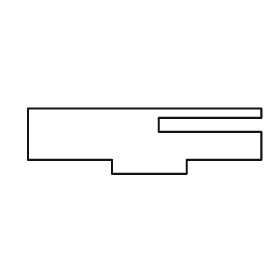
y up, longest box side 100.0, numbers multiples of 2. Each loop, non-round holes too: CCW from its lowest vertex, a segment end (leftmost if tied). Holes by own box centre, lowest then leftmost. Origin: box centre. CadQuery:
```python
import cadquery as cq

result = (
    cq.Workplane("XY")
    .moveTo(-14.0, -14.0)
    .lineTo(18.0, -14.0)
    .lineTo(18.0, -8.0)
    .lineTo(50.0, -8.0)
    .lineTo(50.0, 4.0)
    .lineTo(6.0, 4.0)
    .lineTo(6.0, 10.0)
    .lineTo(50.0, 10.0)
    .lineTo(50.0, 14.0)
    .lineTo(-50.0, 14.0)
    .lineTo(-50.0, -8.0)
    .lineTo(-14.0, -8.0)
    .close()
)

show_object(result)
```